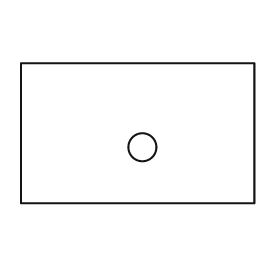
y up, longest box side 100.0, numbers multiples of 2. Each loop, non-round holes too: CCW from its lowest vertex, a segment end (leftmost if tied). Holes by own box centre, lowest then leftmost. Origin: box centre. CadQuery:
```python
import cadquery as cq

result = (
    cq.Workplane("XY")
    .moveTo(-50.0, -30.0)
    .lineTo(50.0, -30.0)
    .lineTo(50.0, 30.0)
    .lineTo(-50.0, 30.0)
    .close()
    .moveTo(2.0, -6.0)
    .circle(6.0)
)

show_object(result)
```